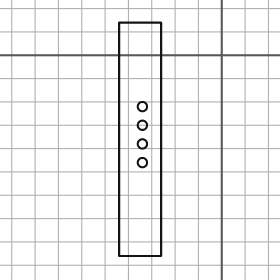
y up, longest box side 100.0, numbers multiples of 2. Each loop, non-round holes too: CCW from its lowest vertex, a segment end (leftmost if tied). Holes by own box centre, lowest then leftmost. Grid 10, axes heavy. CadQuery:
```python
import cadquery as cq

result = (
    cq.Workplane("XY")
    .moveTo(-44.0, -86.0)
    .lineTo(-26.0, -86.0)
    .lineTo(-26.0, 14.0)
    .lineTo(-44.0, 14.0)
    .close()
    .moveTo(-34.0, -46.0)
    .circle(2.0)
    .moveTo(-34.0, -38.0)
    .circle(2.0)
    .moveTo(-34.0, -30.0)
    .circle(2.0)
    .moveTo(-34.0, -22.0)
    .circle(2.0)
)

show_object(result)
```